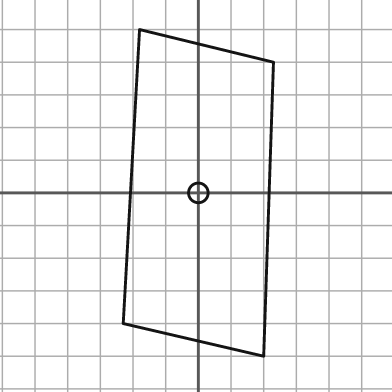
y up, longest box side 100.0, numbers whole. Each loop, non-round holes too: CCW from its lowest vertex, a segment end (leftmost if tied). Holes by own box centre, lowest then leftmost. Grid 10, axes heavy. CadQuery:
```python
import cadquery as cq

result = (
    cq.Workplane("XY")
    .moveTo(20.0, -50.0)
    .lineTo(23.0, 40.0)
    .lineTo(-18.0, 50.0)
    .lineTo(-23.0, -40.0)
    .close()
    .moveTo(0.0, 0.0)
    .circle(3.0)
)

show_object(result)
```